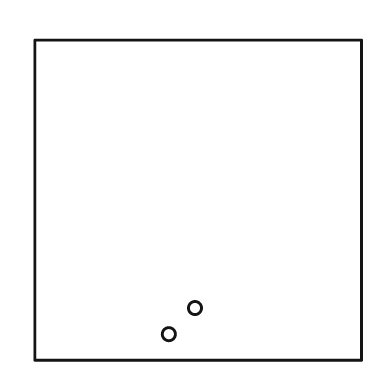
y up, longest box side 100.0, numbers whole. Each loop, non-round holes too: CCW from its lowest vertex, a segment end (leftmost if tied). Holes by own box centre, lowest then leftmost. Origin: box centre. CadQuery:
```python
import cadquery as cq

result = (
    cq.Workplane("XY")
    .moveTo(-50.0, -49.0)
    .lineTo(50.0, -49.0)
    .lineTo(50.0, 49.0)
    .lineTo(-50.0, 49.0)
    .close()
    .moveTo(-9.0, -41.0)
    .circle(2.0)
    .moveTo(-1.0, -33.0)
    .circle(2.0)
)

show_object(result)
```